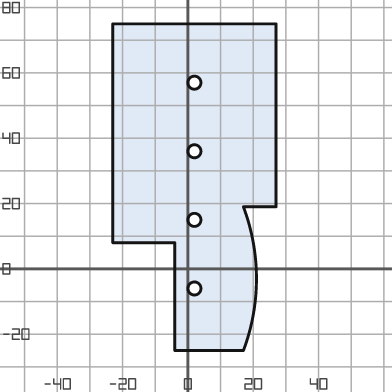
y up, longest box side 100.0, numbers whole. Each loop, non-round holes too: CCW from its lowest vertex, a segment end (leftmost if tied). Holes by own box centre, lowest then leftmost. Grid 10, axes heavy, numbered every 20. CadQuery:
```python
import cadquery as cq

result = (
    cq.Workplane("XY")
    .moveTo(-4.0, -25.0)
    .lineTo(17.0, -25.0)
    .threePointArc((21.0, -3.0), (17.0, 19.0))
    .lineTo(27.0, 19.0)
    .lineTo(27.0, 75.0)
    .lineTo(-23.0, 75.0)
    .lineTo(-23.0, 8.0)
    .lineTo(-4.0, 8.0)
    .close()
    .moveTo(2.0, -6.0)
    .circle(2.0)
    .moveTo(2.0, 15.0)
    .circle(2.0)
    .moveTo(2.0, 36.0)
    .circle(2.0)
    .moveTo(2.0, 57.0)
    .circle(2.0)
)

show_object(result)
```